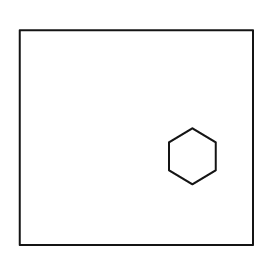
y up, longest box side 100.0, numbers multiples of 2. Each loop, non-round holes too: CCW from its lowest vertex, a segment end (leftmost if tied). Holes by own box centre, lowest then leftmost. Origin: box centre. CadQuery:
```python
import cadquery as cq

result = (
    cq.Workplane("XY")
    .moveTo(-50.0, -46.0)
    .lineTo(50.0, -46.0)
    .lineTo(50.0, 46.0)
    .lineTo(-50.0, 46.0)
    .close()
    .moveTo(24.0, -20.0)
    .lineTo(34.0, -14.0)
    .lineTo(34.0, -2.0)
    .lineTo(24.0, 4.0)
    .lineTo(14.0, -2.0)
    .lineTo(14.0, -14.0)
    .close()
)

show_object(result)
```